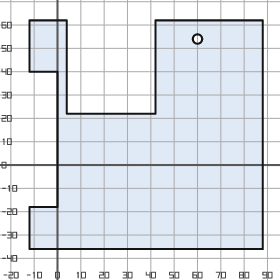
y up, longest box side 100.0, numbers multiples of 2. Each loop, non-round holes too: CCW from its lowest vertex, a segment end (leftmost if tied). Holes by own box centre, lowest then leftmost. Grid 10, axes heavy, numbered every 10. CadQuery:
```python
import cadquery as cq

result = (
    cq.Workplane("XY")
    .moveTo(-12.0, -36.0)
    .lineTo(88.0, -36.0)
    .lineTo(88.0, 62.0)
    .lineTo(42.0, 62.0)
    .lineTo(42.0, 22.0)
    .lineTo(4.0, 22.0)
    .lineTo(4.0, 62.0)
    .lineTo(-12.0, 62.0)
    .lineTo(-12.0, 40.0)
    .lineTo(0.0, 40.0)
    .lineTo(0.0, -18.0)
    .lineTo(-12.0, -18.0)
    .close()
    .moveTo(60.0, 54.0)
    .circle(2.0)
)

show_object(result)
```